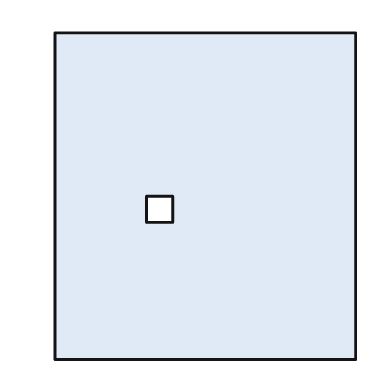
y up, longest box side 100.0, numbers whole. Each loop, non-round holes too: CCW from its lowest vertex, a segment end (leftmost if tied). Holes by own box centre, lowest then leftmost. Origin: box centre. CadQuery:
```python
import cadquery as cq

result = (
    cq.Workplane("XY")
    .moveTo(-46.0, -50.0)
    .lineTo(46.0, -50.0)
    .lineTo(46.0, 50.0)
    .lineTo(-46.0, 50.0)
    .close()
    .moveTo(-18.0, -8.0)
    .lineTo(-10.0, -8.0)
    .lineTo(-10.0, 0.0)
    .lineTo(-18.0, 0.0)
    .close()
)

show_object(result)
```